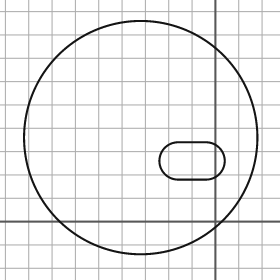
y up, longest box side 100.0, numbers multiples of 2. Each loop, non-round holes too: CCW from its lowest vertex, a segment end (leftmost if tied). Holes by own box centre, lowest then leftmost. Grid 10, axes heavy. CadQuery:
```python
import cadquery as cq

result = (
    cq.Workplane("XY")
    .moveTo(-32.0, 36.0)
    .circle(50.0)
    .moveTo(-16.0, 18.0)
    .lineTo(-4.0, 18.0)
    .threePointArc((4.0, 26.0), (-4.0, 34.0))
    .lineTo(-16.0, 34.0)
    .threePointArc((-24.0, 26.0), (-16.0, 18.0))
    .close()
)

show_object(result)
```